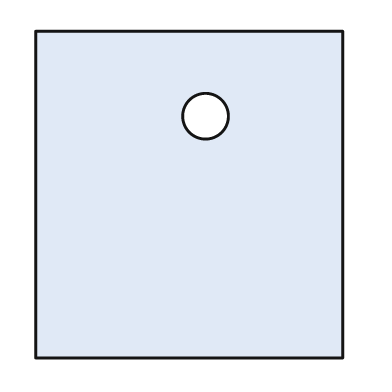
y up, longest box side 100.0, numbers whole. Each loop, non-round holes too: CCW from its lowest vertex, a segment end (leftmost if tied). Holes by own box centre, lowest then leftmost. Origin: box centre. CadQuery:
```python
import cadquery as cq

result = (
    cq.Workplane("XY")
    .moveTo(-47.0, -50.0)
    .lineTo(47.0, -50.0)
    .lineTo(47.0, 50.0)
    .lineTo(-47.0, 50.0)
    .close()
    .moveTo(5.0, 24.0)
    .circle(7.0)
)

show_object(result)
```